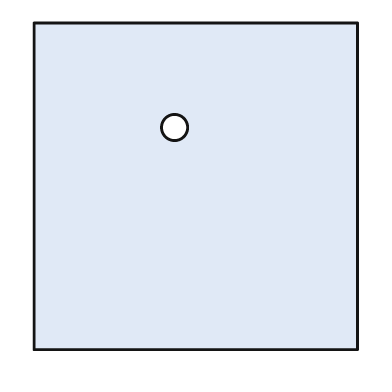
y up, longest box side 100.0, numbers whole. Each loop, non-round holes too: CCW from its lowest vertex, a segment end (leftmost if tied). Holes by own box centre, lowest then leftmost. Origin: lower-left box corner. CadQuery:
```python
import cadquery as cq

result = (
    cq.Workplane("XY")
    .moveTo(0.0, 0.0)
    .lineTo(99.0, 0.0)
    .lineTo(99.0, 100.0)
    .lineTo(0.0, 100.0)
    .close()
    .moveTo(43.0, 68.0)
    .circle(4.0)
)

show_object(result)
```